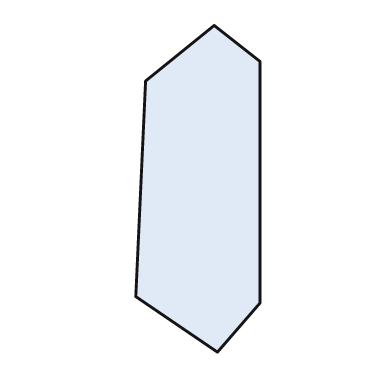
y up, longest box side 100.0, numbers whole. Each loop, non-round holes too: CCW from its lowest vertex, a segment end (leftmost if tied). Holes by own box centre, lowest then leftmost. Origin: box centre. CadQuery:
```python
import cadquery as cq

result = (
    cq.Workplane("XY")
    .moveTo(6.0, -50.0)
    .lineTo(19.0, -35.0)
    .lineTo(19.0, 39.0)
    .lineTo(5.0, 50.0)
    .lineTo(-16.0, 33.0)
    .lineTo(-19.0, -33.0)
    .close()
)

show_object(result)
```